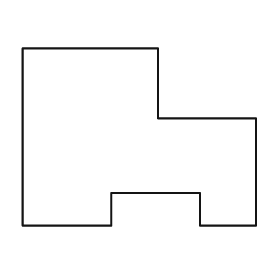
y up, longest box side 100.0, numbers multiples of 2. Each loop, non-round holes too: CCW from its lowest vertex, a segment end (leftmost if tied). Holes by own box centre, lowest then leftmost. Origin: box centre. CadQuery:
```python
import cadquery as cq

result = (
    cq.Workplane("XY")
    .moveTo(-50.0, -38.0)
    .lineTo(-12.0, -38.0)
    .lineTo(-12.0, -24.0)
    .lineTo(26.0, -24.0)
    .lineTo(26.0, -38.0)
    .lineTo(50.0, -38.0)
    .lineTo(50.0, 8.0)
    .lineTo(8.0, 8.0)
    .lineTo(8.0, 38.0)
    .lineTo(-50.0, 38.0)
    .close()
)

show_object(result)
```